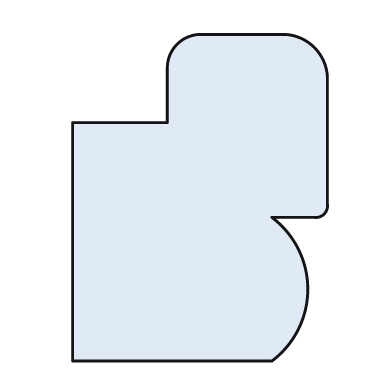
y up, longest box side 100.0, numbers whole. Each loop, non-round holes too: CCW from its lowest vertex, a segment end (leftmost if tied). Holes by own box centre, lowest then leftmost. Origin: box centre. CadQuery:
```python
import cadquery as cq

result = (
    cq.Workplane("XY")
    .moveTo(-39.0, -50.0)
    .lineTo(22.0, -50.0)
    .threePointArc((33.0, -28.0), (22.0, -6.0))
    .lineTo(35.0, -6.0)
    .threePointArc((38.0, -5.0), (39.0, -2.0))
    .lineTo(39.0, 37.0)
    .threePointArc((35.0, 46.0), (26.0, 50.0))
    .lineTo(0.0, 50.0)
    .threePointArc((-7.0, 47.0), (-10.0, 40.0))
    .lineTo(-10.0, 23.0)
    .lineTo(-39.0, 23.0)
    .close()
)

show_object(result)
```